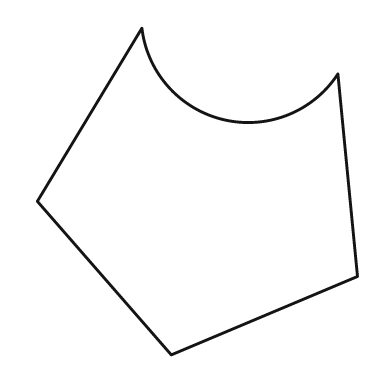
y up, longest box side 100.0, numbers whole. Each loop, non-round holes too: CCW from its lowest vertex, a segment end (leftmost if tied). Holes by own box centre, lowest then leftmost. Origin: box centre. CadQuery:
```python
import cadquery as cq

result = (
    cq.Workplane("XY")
    .moveTo(-8.0, -50.0)
    .lineTo(49.0, -26.0)
    .lineTo(43.0, 36.0)
    .threePointArc((8.0, 22.0), (-17.0, 50.0))
    .lineTo(-49.0, -3.0)
    .close()
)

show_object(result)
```